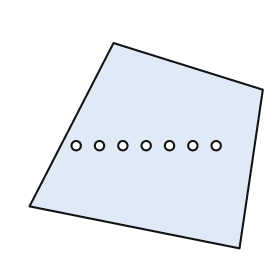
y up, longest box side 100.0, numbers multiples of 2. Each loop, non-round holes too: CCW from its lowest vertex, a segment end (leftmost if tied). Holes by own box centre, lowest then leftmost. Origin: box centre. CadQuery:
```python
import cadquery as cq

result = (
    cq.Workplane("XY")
    .moveTo(40.0, -44.0)
    .lineTo(50.0, 24.0)
    .lineTo(-14.0, 44.0)
    .lineTo(-50.0, -26.0)
    .close()
    .moveTo(-30.0, 0.0)
    .circle(2.0)
    .moveTo(-20.0, 0.0)
    .circle(2.0)
    .moveTo(-10.0, 0.0)
    .circle(2.0)
    .moveTo(0.0, 0.0)
    .circle(2.0)
    .moveTo(10.0, 0.0)
    .circle(2.0)
    .moveTo(20.0, 0.0)
    .circle(2.0)
    .moveTo(30.0, 0.0)
    .circle(2.0)
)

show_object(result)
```